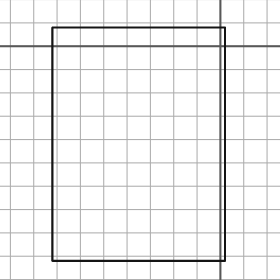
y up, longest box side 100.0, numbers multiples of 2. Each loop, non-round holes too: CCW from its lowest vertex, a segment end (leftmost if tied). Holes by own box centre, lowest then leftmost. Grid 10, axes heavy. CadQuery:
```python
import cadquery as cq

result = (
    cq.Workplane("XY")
    .moveTo(-72.0, -92.0)
    .lineTo(2.0, -92.0)
    .lineTo(2.0, 8.0)
    .lineTo(-72.0, 8.0)
    .close()
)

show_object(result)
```